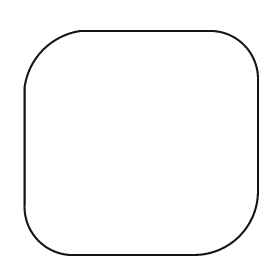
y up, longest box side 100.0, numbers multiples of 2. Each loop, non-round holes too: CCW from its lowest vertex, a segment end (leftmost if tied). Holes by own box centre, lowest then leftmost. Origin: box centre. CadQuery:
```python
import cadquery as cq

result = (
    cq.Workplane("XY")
    .moveTo(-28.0, -48.0)
    .lineTo(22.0, -48.0)
    .threePointArc((42.0, -40.0), (50.0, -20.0))
    .lineTo(50.0, 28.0)
    .threePointArc((44.0, 42.0), (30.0, 48.0))
    .lineTo(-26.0, 48.0)
    .threePointArc((-42.0, 40.0), (-50.0, 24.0))
    .lineTo(-50.0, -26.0)
    .threePointArc((-44.0, -42.0), (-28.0, -48.0))
    .close()
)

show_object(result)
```